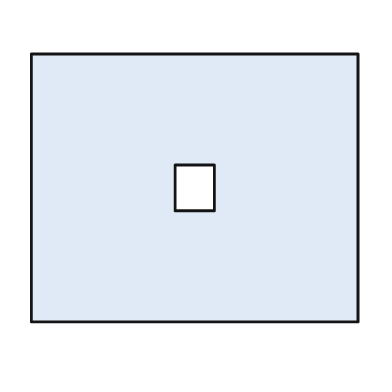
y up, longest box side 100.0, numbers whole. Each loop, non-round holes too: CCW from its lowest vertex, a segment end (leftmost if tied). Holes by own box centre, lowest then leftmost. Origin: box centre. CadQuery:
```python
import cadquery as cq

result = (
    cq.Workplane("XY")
    .moveTo(-50.0, -41.0)
    .lineTo(50.0, -41.0)
    .lineTo(50.0, 41.0)
    .lineTo(-50.0, 41.0)
    .close()
    .moveTo(-6.0, -7.0)
    .lineTo(6.0, -7.0)
    .lineTo(6.0, 7.0)
    .lineTo(-6.0, 7.0)
    .close()
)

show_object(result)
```